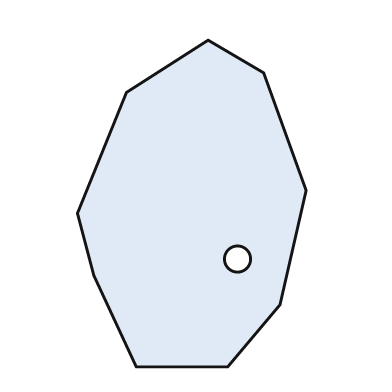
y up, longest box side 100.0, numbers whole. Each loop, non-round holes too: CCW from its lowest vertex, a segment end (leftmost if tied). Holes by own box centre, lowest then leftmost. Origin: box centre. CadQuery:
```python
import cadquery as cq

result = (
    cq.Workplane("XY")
    .moveTo(-17.0, -50.0)
    .lineTo(11.0, -50.0)
    .lineTo(27.0, -31.0)
    .lineTo(35.0, 4.0)
    .lineTo(22.0, 40.0)
    .lineTo(5.0, 50.0)
    .lineTo(-20.0, 34.0)
    .lineTo(-35.0, -3.0)
    .lineTo(-30.0, -22.0)
    .close()
    .moveTo(14.0, -17.0)
    .circle(4.0)
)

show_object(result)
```